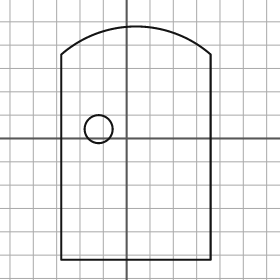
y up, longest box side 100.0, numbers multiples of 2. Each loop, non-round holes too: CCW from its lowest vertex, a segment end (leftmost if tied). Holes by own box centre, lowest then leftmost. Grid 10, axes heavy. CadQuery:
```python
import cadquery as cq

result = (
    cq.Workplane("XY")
    .moveTo(-28.0, -52.0)
    .lineTo(36.0, -52.0)
    .lineTo(36.0, 36.0)
    .threePointArc((4.0, 48.0), (-28.0, 36.0))
    .close()
    .moveTo(-12.0, 4.0)
    .circle(6.0)
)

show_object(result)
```